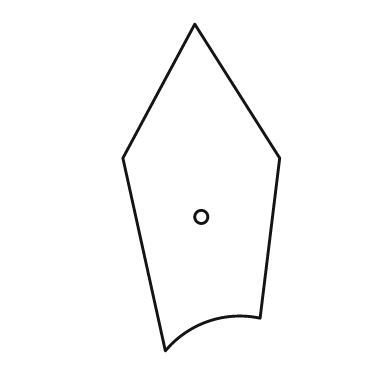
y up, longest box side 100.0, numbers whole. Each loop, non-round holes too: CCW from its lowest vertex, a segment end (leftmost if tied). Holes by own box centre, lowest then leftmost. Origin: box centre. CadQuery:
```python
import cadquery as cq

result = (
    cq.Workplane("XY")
    .moveTo(-11.0, -50.0)
    .threePointArc((2.0, -41.0), (18.0, -40.0))
    .lineTo(24.0, 9.0)
    .lineTo(-2.0, 50.0)
    .lineTo(-24.0, 9.0)
    .close()
    .moveTo(0.0, -9.0)
    .circle(2.0)
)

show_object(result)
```